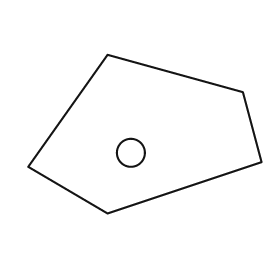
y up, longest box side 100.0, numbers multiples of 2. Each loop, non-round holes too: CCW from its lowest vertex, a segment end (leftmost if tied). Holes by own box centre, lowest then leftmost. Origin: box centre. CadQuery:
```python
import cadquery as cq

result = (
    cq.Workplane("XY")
    .moveTo(-16.0, -34.0)
    .lineTo(50.0, -12.0)
    .lineTo(42.0, 18.0)
    .lineTo(-16.0, 34.0)
    .lineTo(-50.0, -14.0)
    .close()
    .moveTo(-6.0, -8.0)
    .circle(6.0)
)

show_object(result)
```